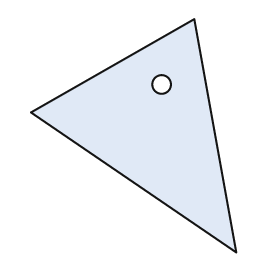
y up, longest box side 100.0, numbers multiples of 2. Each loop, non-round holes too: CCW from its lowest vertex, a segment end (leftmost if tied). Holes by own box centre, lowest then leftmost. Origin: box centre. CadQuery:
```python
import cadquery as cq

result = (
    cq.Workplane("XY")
    .moveTo(44.0, -50.0)
    .lineTo(26.0, 50.0)
    .lineTo(-44.0, 10.0)
    .close()
    .moveTo(12.0, 22.0)
    .circle(4.0)
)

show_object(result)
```